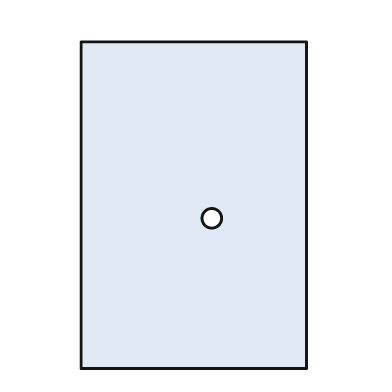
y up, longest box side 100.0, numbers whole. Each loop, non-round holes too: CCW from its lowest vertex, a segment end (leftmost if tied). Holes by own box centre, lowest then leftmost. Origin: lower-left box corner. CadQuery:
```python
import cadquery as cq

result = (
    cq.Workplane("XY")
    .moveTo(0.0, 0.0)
    .lineTo(69.0, 0.0)
    .lineTo(69.0, 100.0)
    .lineTo(0.0, 100.0)
    .close()
    .moveTo(40.0, 46.0)
    .circle(3.0)
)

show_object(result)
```